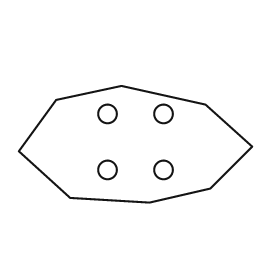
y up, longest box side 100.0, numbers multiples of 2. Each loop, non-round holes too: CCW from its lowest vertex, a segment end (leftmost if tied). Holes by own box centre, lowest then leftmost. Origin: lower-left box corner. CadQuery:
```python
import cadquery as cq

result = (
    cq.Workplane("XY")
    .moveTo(56.0, 0.0)
    .lineTo(82.0, 6.0)
    .lineTo(100.0, 24.0)
    .lineTo(80.0, 42.0)
    .lineTo(44.0, 50.0)
    .lineTo(16.0, 44.0)
    .lineTo(0.0, 22.0)
    .lineTo(22.0, 2.0)
    .close()
    .moveTo(38.0, 14.0)
    .circle(4.0)
    .moveTo(62.0, 14.0)
    .circle(4.0)
    .moveTo(38.0, 38.0)
    .circle(4.0)
    .moveTo(62.0, 38.0)
    .circle(4.0)
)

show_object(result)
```